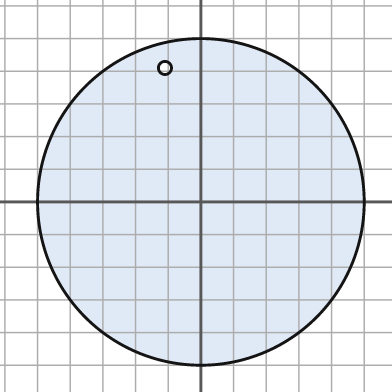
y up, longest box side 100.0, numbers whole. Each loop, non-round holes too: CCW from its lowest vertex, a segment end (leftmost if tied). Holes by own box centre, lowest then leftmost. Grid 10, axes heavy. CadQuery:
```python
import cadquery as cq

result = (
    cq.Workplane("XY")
    .moveTo(0.0, 0.0)
    .circle(50.0)
    .moveTo(-11.0, 41.0)
    .circle(2.0)
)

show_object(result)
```